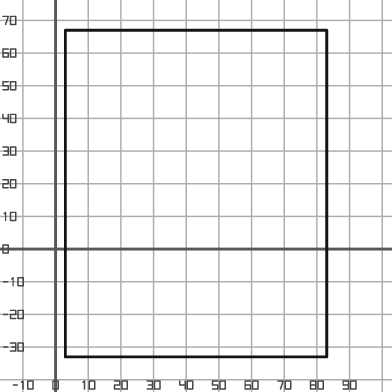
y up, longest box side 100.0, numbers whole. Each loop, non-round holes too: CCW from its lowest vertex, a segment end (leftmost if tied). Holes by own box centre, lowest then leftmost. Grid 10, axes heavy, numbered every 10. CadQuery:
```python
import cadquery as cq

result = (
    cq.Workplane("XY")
    .moveTo(3.0, -33.0)
    .lineTo(83.0, -33.0)
    .lineTo(83.0, 67.0)
    .lineTo(3.0, 67.0)
    .close()
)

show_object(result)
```